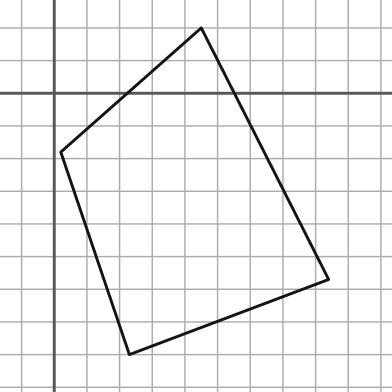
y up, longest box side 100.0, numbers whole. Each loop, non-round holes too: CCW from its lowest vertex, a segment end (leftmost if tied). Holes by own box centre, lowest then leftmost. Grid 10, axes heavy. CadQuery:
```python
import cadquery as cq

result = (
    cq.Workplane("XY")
    .moveTo(23.0, -80.0)
    .lineTo(84.0, -57.0)
    .lineTo(45.0, 20.0)
    .lineTo(2.0, -18.0)
    .close()
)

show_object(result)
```